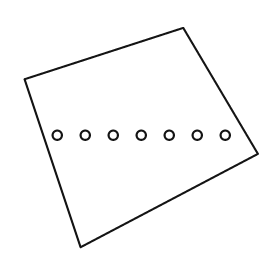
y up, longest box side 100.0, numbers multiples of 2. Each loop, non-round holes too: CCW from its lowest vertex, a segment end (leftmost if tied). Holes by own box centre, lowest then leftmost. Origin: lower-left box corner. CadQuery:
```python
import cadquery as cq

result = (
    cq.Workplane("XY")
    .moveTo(24.0, 0.0)
    .lineTo(100.0, 40.0)
    .lineTo(68.0, 94.0)
    .lineTo(0.0, 72.0)
    .close()
    .moveTo(14.0, 48.0)
    .circle(2.0)
    .moveTo(26.0, 48.0)
    .circle(2.0)
    .moveTo(38.0, 48.0)
    .circle(2.0)
    .moveTo(50.0, 48.0)
    .circle(2.0)
    .moveTo(62.0, 48.0)
    .circle(2.0)
    .moveTo(74.0, 48.0)
    .circle(2.0)
    .moveTo(86.0, 48.0)
    .circle(2.0)
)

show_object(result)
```